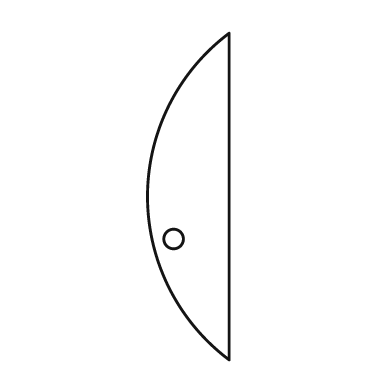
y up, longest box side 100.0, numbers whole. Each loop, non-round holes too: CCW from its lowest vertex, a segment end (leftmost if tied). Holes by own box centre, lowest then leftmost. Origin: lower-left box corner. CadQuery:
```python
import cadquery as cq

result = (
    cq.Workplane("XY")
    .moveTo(25.0, 0.0)
    .lineTo(25.0, 100.0)
    .threePointArc((0.0, 50.0), (25.0, 0.0))
    .close()
    .moveTo(8.0, 37.0)
    .circle(3.0)
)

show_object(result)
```